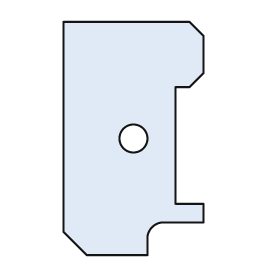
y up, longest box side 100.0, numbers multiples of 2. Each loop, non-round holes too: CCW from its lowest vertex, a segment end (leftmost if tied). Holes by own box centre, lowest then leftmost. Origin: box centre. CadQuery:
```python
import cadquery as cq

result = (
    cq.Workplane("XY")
    .moveTo(-20.0, -50.0)
    .lineTo(6.0, -50.0)
    .lineTo(6.0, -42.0)
    .threePointArc((8.0, -38.0), (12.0, -36.0))
    .lineTo(30.0, -36.0)
    .lineTo(30.0, -28.0)
    .lineTo(18.0, -28.0)
    .lineTo(18.0, 22.0)
    .lineTo(24.0, 22.0)
    .lineTo(30.0, 28.0)
    .lineTo(30.0, 44.0)
    .lineTo(24.0, 50.0)
    .lineTo(-30.0, 50.0)
    .lineTo(-30.0, -40.0)
    .close()
    .moveTo(0.0, 0.0)
    .circle(6.0)
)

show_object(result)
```